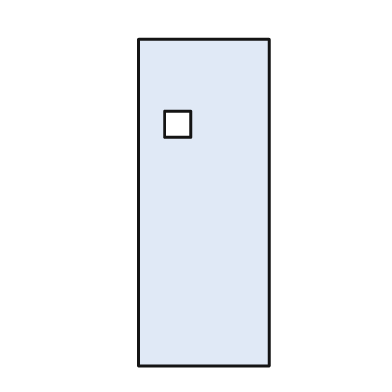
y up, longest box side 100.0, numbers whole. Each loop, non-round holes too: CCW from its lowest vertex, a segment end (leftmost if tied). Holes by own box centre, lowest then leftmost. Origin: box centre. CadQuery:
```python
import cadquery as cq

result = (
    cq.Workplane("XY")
    .moveTo(-20.0, -50.0)
    .lineTo(20.0, -50.0)
    .lineTo(20.0, 50.0)
    .lineTo(-20.0, 50.0)
    .close()
    .moveTo(-12.0, 20.0)
    .lineTo(-4.0, 20.0)
    .lineTo(-4.0, 28.0)
    .lineTo(-12.0, 28.0)
    .close()
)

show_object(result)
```